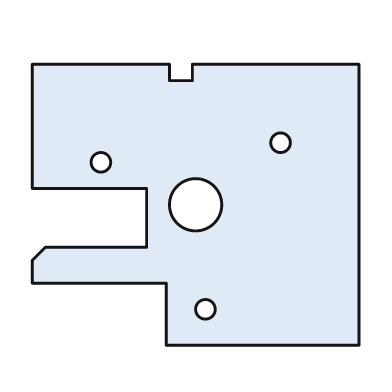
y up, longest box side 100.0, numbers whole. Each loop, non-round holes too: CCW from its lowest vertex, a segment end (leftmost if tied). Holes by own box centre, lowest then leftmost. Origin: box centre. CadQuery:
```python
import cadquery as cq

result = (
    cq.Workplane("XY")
    .moveTo(-9.0, -43.0)
    .lineTo(50.0, -43.0)
    .lineTo(50.0, 43.0)
    .lineTo(-1.0, 43.0)
    .lineTo(-1.0, 38.0)
    .lineTo(-8.0, 38.0)
    .lineTo(-8.0, 43.0)
    .lineTo(-50.0, 43.0)
    .lineTo(-50.0, 5.0)
    .lineTo(-15.0, 5.0)
    .lineTo(-15.0, -13.0)
    .lineTo(-46.0, -13.0)
    .lineTo(-50.0, -17.0)
    .lineTo(-50.0, -24.0)
    .lineTo(-9.0, -24.0)
    .close()
    .moveTo(3.0, -32.0)
    .circle(3.0)
    .moveTo(0.0, 0.0)
    .circle(8.0)
    .moveTo(-29.0, 13.0)
    .circle(3.0)
    .moveTo(26.0, 19.0)
    .circle(3.0)
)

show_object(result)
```